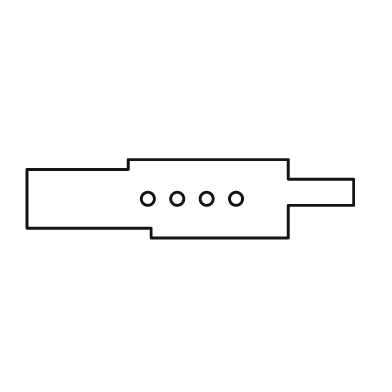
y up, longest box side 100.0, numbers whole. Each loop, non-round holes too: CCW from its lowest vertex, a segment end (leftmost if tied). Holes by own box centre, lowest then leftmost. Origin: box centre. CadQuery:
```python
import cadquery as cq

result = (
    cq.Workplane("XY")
    .moveTo(-12.0, -12.0)
    .lineTo(30.0, -12.0)
    .lineTo(30.0, -2.0)
    .lineTo(50.0, -2.0)
    .lineTo(50.0, 6.0)
    .lineTo(30.0, 6.0)
    .lineTo(30.0, 12.0)
    .lineTo(-19.0, 12.0)
    .lineTo(-19.0, 9.0)
    .lineTo(-50.0, 9.0)
    .lineTo(-50.0, -9.0)
    .lineTo(-12.0, -9.0)
    .close()
    .moveTo(-13.0, 0.0)
    .circle(2.0)
    .moveTo(-4.0, 0.0)
    .circle(2.0)
    .moveTo(5.0, 0.0)
    .circle(2.0)
    .moveTo(14.0, 0.0)
    .circle(2.0)
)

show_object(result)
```